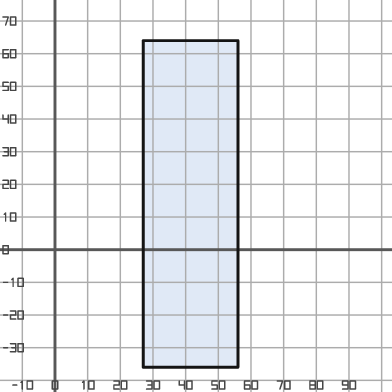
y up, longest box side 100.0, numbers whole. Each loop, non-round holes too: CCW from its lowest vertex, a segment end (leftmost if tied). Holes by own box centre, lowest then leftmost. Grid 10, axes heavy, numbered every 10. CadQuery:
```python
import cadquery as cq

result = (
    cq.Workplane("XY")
    .moveTo(27.0, -36.0)
    .lineTo(56.0, -36.0)
    .lineTo(56.0, 64.0)
    .lineTo(27.0, 64.0)
    .close()
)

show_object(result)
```